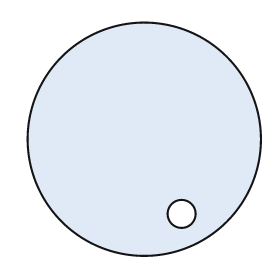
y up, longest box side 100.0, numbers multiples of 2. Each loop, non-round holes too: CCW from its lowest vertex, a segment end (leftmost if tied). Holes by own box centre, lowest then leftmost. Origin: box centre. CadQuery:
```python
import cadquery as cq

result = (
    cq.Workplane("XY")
    .moveTo(0.0, 0.0)
    .circle(50.0)
    .moveTo(16.0, -32.0)
    .circle(6.0)
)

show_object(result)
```